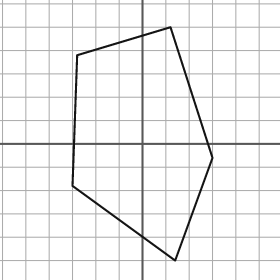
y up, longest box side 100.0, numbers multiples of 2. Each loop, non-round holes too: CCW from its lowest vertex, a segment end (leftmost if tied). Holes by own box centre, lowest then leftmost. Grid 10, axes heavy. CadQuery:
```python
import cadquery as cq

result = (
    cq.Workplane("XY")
    .moveTo(14.0, -50.0)
    .lineTo(30.0, -6.0)
    .lineTo(12.0, 50.0)
    .lineTo(-28.0, 38.0)
    .lineTo(-30.0, -18.0)
    .close()
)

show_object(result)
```